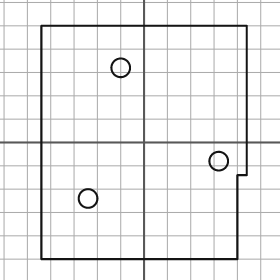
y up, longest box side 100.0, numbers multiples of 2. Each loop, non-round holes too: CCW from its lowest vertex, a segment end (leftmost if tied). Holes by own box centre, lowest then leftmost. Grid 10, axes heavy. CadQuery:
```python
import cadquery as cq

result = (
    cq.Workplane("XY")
    .moveTo(-44.0, -50.0)
    .lineTo(40.0, -50.0)
    .lineTo(40.0, -14.0)
    .lineTo(44.0, -14.0)
    .lineTo(44.0, 50.0)
    .lineTo(-44.0, 50.0)
    .close()
    .moveTo(-24.0, -24.0)
    .circle(4.0)
    .moveTo(32.0, -8.0)
    .circle(4.0)
    .moveTo(-10.0, 32.0)
    .circle(4.0)
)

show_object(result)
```